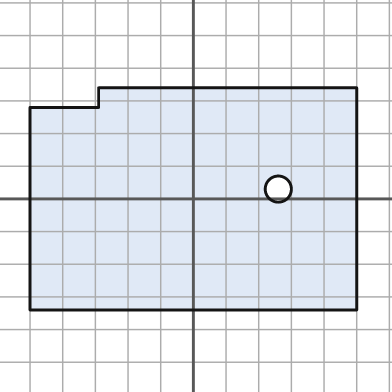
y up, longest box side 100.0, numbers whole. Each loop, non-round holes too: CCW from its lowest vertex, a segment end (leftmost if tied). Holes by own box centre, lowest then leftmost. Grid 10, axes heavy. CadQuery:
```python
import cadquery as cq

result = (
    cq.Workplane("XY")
    .moveTo(-50.0, -34.0)
    .lineTo(50.0, -34.0)
    .lineTo(50.0, 34.0)
    .lineTo(-29.0, 34.0)
    .lineTo(-29.0, 28.0)
    .lineTo(-50.0, 28.0)
    .close()
    .moveTo(26.0, 3.0)
    .circle(4.0)
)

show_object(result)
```